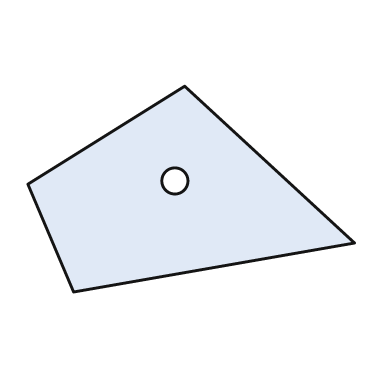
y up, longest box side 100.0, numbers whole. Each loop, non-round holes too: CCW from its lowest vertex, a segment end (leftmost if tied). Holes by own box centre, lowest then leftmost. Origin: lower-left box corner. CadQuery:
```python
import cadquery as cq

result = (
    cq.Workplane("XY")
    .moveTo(14.0, 0.0)
    .lineTo(100.0, 15.0)
    .lineTo(48.0, 63.0)
    .lineTo(0.0, 33.0)
    .close()
    .moveTo(45.0, 34.0)
    .circle(4.0)
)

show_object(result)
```